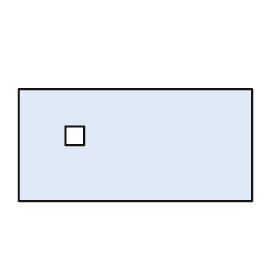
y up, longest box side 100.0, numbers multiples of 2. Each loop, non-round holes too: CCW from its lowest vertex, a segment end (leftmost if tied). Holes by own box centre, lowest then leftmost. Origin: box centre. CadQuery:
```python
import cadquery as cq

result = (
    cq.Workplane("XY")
    .moveTo(-50.0, -24.0)
    .lineTo(50.0, -24.0)
    .lineTo(50.0, 24.0)
    .lineTo(-50.0, 24.0)
    .close()
    .moveTo(-30.0, 0.0)
    .lineTo(-22.0, 0.0)
    .lineTo(-22.0, 8.0)
    .lineTo(-30.0, 8.0)
    .close()
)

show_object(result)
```